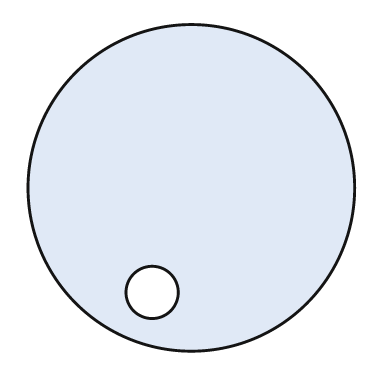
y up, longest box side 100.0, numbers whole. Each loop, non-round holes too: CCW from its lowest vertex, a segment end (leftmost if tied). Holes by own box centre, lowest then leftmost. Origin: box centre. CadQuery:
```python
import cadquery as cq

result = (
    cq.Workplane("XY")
    .moveTo(0.0, 0.0)
    .circle(50.0)
    .moveTo(-12.0, -32.0)
    .circle(8.0)
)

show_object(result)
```